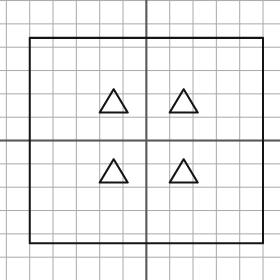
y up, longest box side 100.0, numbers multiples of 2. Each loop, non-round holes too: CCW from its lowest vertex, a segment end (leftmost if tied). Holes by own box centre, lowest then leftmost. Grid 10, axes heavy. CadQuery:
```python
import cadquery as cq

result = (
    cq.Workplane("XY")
    .moveTo(-50.0, -44.0)
    .lineTo(50.0, -44.0)
    .lineTo(50.0, 44.0)
    .lineTo(-50.0, 44.0)
    .close()
    .moveTo(-20.0, -18.0)
    .lineTo(-8.0, -18.0)
    .lineTo(-14.0, -8.0)
    .close()
    .moveTo(10.0, -18.0)
    .lineTo(22.0, -18.0)
    .lineTo(16.0, -8.0)
    .close()
    .moveTo(-20.0, 12.0)
    .lineTo(-8.0, 12.0)
    .lineTo(-14.0, 22.0)
    .close()
    .moveTo(10.0, 12.0)
    .lineTo(22.0, 12.0)
    .lineTo(16.0, 22.0)
    .close()
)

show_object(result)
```